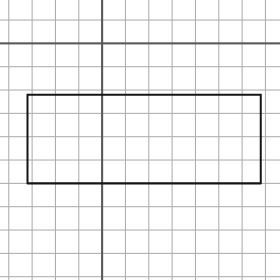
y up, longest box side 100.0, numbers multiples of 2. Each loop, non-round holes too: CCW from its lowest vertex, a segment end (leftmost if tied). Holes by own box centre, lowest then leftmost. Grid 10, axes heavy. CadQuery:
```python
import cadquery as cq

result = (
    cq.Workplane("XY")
    .moveTo(-32.0, -60.0)
    .lineTo(68.0, -60.0)
    .lineTo(68.0, -22.0)
    .lineTo(-32.0, -22.0)
    .close()
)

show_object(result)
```